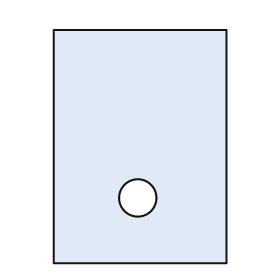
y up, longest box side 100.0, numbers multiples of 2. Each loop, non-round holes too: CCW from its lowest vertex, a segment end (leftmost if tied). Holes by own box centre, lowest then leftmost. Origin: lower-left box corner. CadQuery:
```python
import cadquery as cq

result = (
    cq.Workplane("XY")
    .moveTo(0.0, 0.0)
    .lineTo(74.0, 0.0)
    .lineTo(74.0, 100.0)
    .lineTo(0.0, 100.0)
    .close()
    .moveTo(36.0, 28.0)
    .circle(8.0)
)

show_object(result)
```